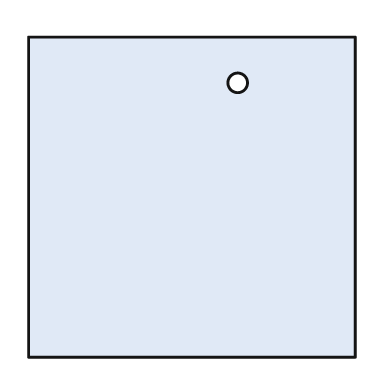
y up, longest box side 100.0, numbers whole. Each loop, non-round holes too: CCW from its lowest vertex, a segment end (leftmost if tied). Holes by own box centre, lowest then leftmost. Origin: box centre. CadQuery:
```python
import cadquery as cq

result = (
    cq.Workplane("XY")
    .moveTo(-50.0, -49.0)
    .lineTo(50.0, -49.0)
    .lineTo(50.0, 49.0)
    .lineTo(-50.0, 49.0)
    .close()
    .moveTo(14.0, 35.0)
    .circle(3.0)
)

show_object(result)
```